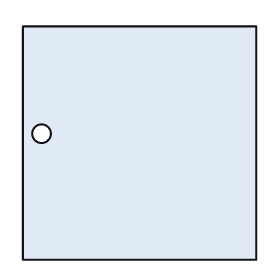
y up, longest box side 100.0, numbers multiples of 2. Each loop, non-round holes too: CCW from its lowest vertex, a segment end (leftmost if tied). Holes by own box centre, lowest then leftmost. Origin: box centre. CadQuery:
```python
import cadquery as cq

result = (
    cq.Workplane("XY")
    .moveTo(-50.0, -50.0)
    .lineTo(50.0, -50.0)
    .lineTo(50.0, 50.0)
    .lineTo(-50.0, 50.0)
    .close()
    .moveTo(-42.0, 4.0)
    .circle(4.0)
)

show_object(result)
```